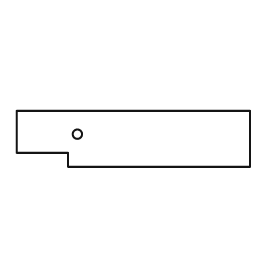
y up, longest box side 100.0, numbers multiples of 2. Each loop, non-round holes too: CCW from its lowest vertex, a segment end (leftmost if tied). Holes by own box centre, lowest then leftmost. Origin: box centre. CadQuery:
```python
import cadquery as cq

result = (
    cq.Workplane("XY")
    .moveTo(-28.0, -12.0)
    .lineTo(50.0, -12.0)
    .lineTo(50.0, 12.0)
    .lineTo(-50.0, 12.0)
    .lineTo(-50.0, -6.0)
    .lineTo(-28.0, -6.0)
    .close()
    .moveTo(-24.0, 2.0)
    .circle(2.0)
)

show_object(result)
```